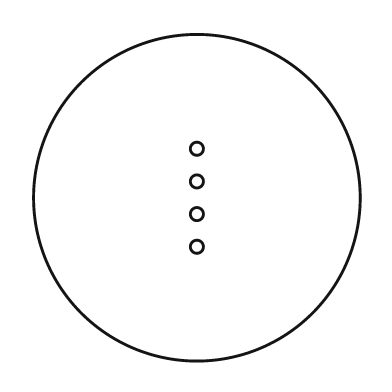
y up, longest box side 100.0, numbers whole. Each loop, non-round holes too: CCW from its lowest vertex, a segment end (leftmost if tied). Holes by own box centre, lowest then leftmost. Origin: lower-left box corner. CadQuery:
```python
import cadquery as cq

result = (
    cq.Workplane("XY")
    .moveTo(50.0, 50.0)
    .circle(50.0)
    .moveTo(50.0, 35.0)
    .circle(2.0)
    .moveTo(50.0, 45.0)
    .circle(2.0)
    .moveTo(50.0, 55.0)
    .circle(2.0)
    .moveTo(50.0, 65.0)
    .circle(2.0)
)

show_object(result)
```